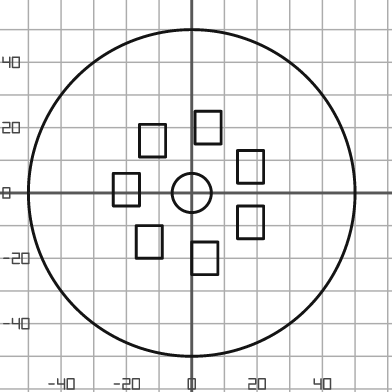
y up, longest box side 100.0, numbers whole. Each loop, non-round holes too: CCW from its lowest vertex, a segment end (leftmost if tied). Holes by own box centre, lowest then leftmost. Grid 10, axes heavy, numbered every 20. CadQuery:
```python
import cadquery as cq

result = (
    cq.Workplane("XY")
    .moveTo(0.0, 0.0)
    .circle(50.0)
    .moveTo(0.0, -25.0)
    .lineTo(8.0, -25.0)
    .lineTo(8.0, -15.0)
    .lineTo(0.0, -15.0)
    .close()
    .moveTo(-17.0, -20.0)
    .lineTo(-9.0, -20.0)
    .lineTo(-9.0, -10.0)
    .lineTo(-17.0, -10.0)
    .close()
    .moveTo(14.0, -14.0)
    .lineTo(22.0, -14.0)
    .lineTo(22.0, -4.0)
    .lineTo(14.0, -4.0)
    .close()
    .moveTo(0.0, 0.0)
    .circle(6.0)
    .moveTo(-24.0, -4.0)
    .lineTo(-16.0, -4.0)
    .lineTo(-16.0, 6.0)
    .lineTo(-24.0, 6.0)
    .close()
    .moveTo(14.0, 3.0)
    .lineTo(22.0, 3.0)
    .lineTo(22.0, 13.0)
    .lineTo(14.0, 13.0)
    .close()
    .moveTo(-16.0, 11.0)
    .lineTo(-8.0, 11.0)
    .lineTo(-8.0, 21.0)
    .lineTo(-16.0, 21.0)
    .close()
    .moveTo(1.0, 15.0)
    .lineTo(9.0, 15.0)
    .lineTo(9.0, 25.0)
    .lineTo(1.0, 25.0)
    .close()
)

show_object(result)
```